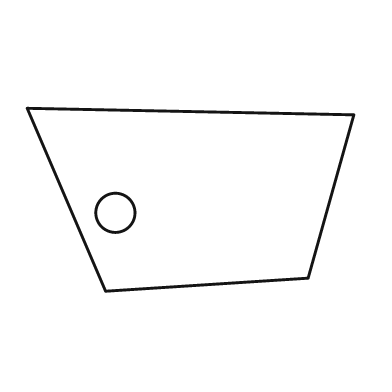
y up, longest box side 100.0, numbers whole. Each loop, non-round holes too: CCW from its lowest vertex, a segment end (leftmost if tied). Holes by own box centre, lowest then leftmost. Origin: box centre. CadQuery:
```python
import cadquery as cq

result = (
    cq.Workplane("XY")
    .moveTo(-26.0, -28.0)
    .lineTo(36.0, -24.0)
    .lineTo(50.0, 26.0)
    .lineTo(-50.0, 28.0)
    .close()
    .moveTo(-23.0, -4.0)
    .circle(6.0)
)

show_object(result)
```